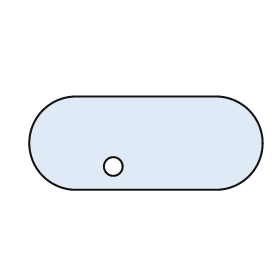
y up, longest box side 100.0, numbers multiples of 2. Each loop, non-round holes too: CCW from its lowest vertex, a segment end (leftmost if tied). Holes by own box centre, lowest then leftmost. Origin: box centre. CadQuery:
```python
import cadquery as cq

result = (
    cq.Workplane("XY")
    .moveTo(-30.0, -20.0)
    .lineTo(30.0, -20.0)
    .threePointArc((50.0, 0.0), (30.0, 20.0))
    .lineTo(-30.0, 20.0)
    .threePointArc((-50.0, 0.0), (-30.0, -20.0))
    .close()
    .moveTo(-14.0, -10.0)
    .circle(4.0)
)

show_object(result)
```